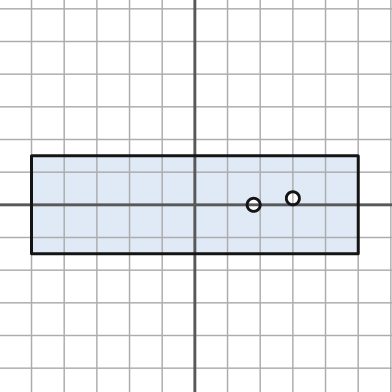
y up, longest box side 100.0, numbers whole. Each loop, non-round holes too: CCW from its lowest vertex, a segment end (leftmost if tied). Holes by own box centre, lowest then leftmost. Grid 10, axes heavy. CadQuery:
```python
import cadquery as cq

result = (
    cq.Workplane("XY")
    .moveTo(-50.0, -15.0)
    .lineTo(50.0, -15.0)
    .lineTo(50.0, 15.0)
    .lineTo(-50.0, 15.0)
    .close()
    .moveTo(18.0, 0.0)
    .circle(2.0)
    .moveTo(30.0, 2.0)
    .circle(2.0)
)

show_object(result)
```